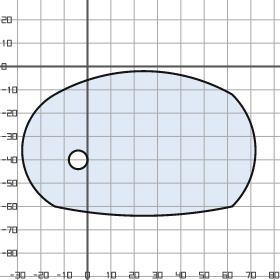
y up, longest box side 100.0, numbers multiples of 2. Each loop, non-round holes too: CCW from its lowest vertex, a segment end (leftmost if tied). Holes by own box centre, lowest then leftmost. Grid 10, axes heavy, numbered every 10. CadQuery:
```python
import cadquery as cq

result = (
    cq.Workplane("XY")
    .moveTo(-14.0, -60.0)
    .threePointArc((24.0, -64.0), (62.0, -60.0))
    .threePointArc((72.0, -36.0), (62.0, -12.0))
    .threePointArc((24.0, -2.0), (-14.0, -12.0))
    .threePointArc((-28.0, -36.0), (-14.0, -60.0))
    .close()
    .moveTo(-4.0, -40.0)
    .circle(4.0)
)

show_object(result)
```